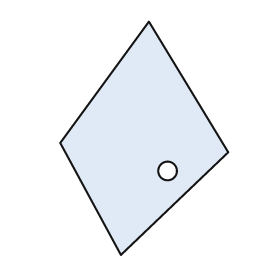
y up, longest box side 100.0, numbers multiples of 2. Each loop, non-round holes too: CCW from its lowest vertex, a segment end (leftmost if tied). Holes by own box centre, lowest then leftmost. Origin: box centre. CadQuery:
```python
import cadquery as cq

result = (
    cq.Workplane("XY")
    .moveTo(-10.0, -50.0)
    .lineTo(36.0, -6.0)
    .lineTo(2.0, 50.0)
    .lineTo(-36.0, -2.0)
    .close()
    .moveTo(10.0, -14.0)
    .circle(4.0)
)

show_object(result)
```